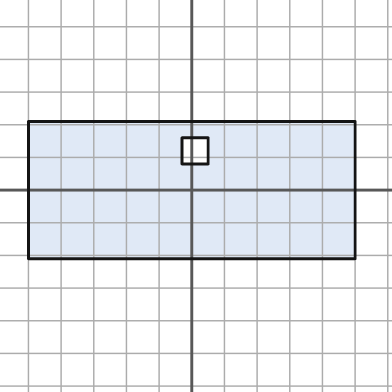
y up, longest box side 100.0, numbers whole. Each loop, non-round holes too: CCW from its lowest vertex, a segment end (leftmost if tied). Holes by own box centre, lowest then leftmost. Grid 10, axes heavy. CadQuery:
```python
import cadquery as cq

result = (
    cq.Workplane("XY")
    .moveTo(-50.0, -21.0)
    .lineTo(50.0, -21.0)
    .lineTo(50.0, 21.0)
    .lineTo(-50.0, 21.0)
    .close()
    .moveTo(-3.0, 8.0)
    .lineTo(5.0, 8.0)
    .lineTo(5.0, 16.0)
    .lineTo(-3.0, 16.0)
    .close()
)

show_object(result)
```